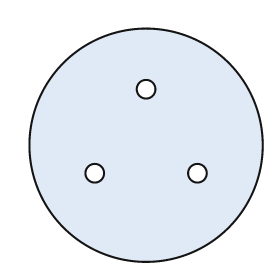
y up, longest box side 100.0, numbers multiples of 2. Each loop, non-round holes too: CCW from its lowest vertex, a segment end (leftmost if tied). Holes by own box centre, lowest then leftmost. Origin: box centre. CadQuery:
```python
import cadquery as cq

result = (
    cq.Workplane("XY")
    .moveTo(0.0, 0.0)
    .circle(50.0)
    .moveTo(-22.0, -12.0)
    .circle(4.0)
    .moveTo(22.0, -12.0)
    .circle(4.0)
    .moveTo(0.0, 24.0)
    .circle(4.0)
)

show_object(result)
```